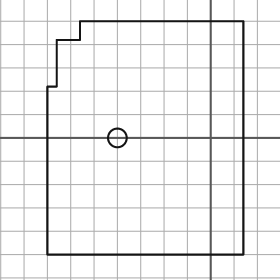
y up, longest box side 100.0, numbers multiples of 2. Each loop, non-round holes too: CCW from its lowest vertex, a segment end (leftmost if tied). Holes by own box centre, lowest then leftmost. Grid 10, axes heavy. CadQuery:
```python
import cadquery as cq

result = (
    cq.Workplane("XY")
    .moveTo(-70.0, -50.0)
    .lineTo(14.0, -50.0)
    .lineTo(14.0, 50.0)
    .lineTo(-56.0, 50.0)
    .lineTo(-56.0, 42.0)
    .lineTo(-66.0, 42.0)
    .lineTo(-66.0, 22.0)
    .lineTo(-70.0, 22.0)
    .close()
    .moveTo(-40.0, 0.0)
    .circle(4.0)
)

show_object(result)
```